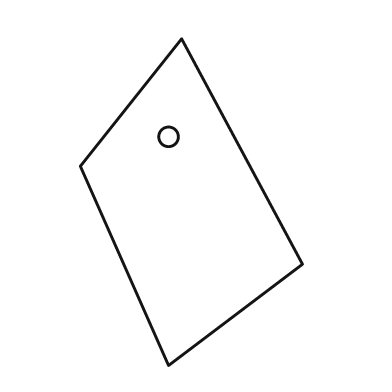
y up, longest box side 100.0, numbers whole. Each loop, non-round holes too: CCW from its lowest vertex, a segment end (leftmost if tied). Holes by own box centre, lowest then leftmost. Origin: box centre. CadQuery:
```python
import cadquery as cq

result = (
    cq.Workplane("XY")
    .moveTo(-7.0, -50.0)
    .lineTo(34.0, -19.0)
    .lineTo(-3.0, 50.0)
    .lineTo(-34.0, 11.0)
    .close()
    .moveTo(-7.0, 20.0)
    .circle(3.0)
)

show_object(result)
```